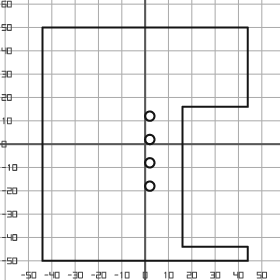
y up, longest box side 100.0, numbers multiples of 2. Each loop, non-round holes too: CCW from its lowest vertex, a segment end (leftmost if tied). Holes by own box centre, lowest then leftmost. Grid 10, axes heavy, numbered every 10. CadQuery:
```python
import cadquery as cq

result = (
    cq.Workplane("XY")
    .moveTo(-44.0, -50.0)
    .lineTo(44.0, -50.0)
    .lineTo(44.0, -44.0)
    .lineTo(16.0, -44.0)
    .lineTo(16.0, 16.0)
    .lineTo(44.0, 16.0)
    .lineTo(44.0, 50.0)
    .lineTo(-44.0, 50.0)
    .close()
    .moveTo(2.0, -18.0)
    .circle(2.0)
    .moveTo(2.0, -8.0)
    .circle(2.0)
    .moveTo(2.0, 2.0)
    .circle(2.0)
    .moveTo(2.0, 12.0)
    .circle(2.0)
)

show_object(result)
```